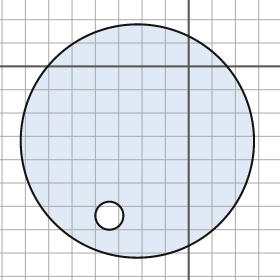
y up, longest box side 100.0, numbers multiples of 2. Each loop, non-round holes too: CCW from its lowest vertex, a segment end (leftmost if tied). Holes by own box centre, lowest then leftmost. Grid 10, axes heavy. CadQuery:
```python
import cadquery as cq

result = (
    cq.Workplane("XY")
    .moveTo(-22.0, -32.0)
    .circle(50.0)
    .moveTo(-34.0, -64.0)
    .circle(6.0)
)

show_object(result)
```